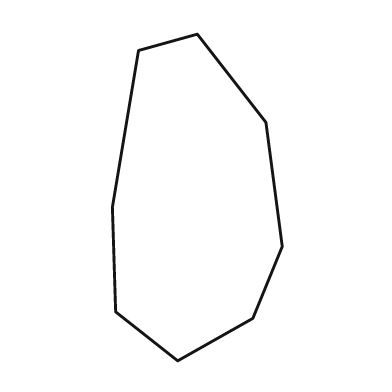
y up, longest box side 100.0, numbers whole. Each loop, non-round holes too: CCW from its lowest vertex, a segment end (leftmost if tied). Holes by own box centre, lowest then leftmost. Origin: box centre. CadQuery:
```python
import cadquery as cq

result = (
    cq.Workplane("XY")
    .moveTo(-6.0, -50.0)
    .lineTo(17.0, -37.0)
    .lineTo(26.0, -15.0)
    .lineTo(21.0, 23.0)
    .lineTo(0.0, 50.0)
    .lineTo(-18.0, 45.0)
    .lineTo(-26.0, -3.0)
    .lineTo(-25.0, -35.0)
    .close()
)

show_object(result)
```